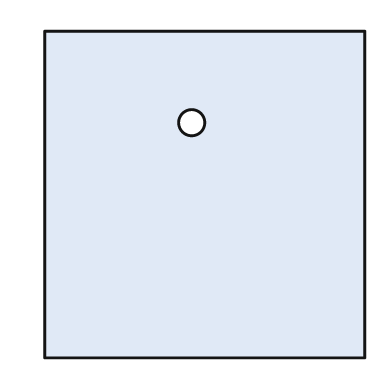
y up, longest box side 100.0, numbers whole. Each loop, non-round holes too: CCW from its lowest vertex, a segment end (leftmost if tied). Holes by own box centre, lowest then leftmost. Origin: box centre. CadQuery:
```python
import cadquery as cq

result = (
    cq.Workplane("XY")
    .moveTo(-49.0, -50.0)
    .lineTo(49.0, -50.0)
    .lineTo(49.0, 50.0)
    .lineTo(-49.0, 50.0)
    .close()
    .moveTo(-4.0, 22.0)
    .circle(4.0)
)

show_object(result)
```